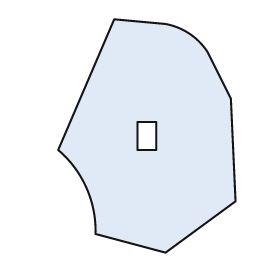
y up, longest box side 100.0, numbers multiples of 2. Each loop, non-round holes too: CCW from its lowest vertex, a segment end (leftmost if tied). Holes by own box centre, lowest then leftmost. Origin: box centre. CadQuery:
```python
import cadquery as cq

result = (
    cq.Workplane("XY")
    .moveTo(8.0, -50.0)
    .lineTo(38.0, -28.0)
    .lineTo(36.0, 16.0)
    .lineTo(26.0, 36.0)
    .threePointArc((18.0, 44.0), (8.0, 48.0))
    .lineTo(-14.0, 50.0)
    .lineTo(-38.0, -6.0)
    .threePointArc((-26.0, -22.0), (-22.0, -42.0))
    .close()
    .moveTo(-4.0, -6.0)
    .lineTo(4.0, -6.0)
    .lineTo(4.0, 6.0)
    .lineTo(-4.0, 6.0)
    .close()
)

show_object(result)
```